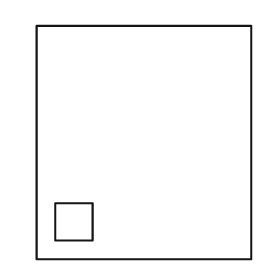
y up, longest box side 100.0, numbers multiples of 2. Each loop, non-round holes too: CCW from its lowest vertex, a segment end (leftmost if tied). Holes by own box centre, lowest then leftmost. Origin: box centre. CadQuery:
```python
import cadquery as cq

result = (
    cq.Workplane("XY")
    .moveTo(-46.0, -50.0)
    .lineTo(46.0, -50.0)
    .lineTo(46.0, 50.0)
    .lineTo(-46.0, 50.0)
    .close()
    .moveTo(-38.0, -42.0)
    .lineTo(-22.0, -42.0)
    .lineTo(-22.0, -26.0)
    .lineTo(-38.0, -26.0)
    .close()
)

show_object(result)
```